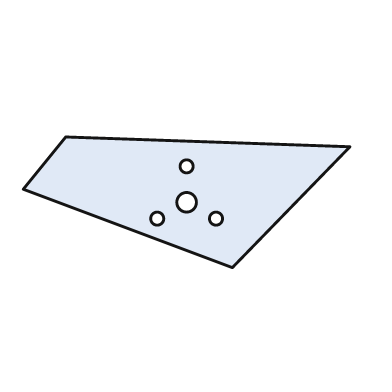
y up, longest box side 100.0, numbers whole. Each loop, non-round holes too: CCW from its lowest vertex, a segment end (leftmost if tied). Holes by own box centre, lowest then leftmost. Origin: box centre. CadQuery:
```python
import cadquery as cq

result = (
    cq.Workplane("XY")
    .moveTo(14.0, -20.0)
    .lineTo(50.0, 17.0)
    .lineTo(-37.0, 20.0)
    .lineTo(-50.0, 4.0)
    .close()
    .moveTo(-9.0, -5.0)
    .circle(2.0)
    .moveTo(9.0, -5.0)
    .circle(2.0)
    .moveTo(0.0, 0.0)
    .circle(3.0)
    .moveTo(0.0, 11.0)
    .circle(2.0)
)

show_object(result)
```